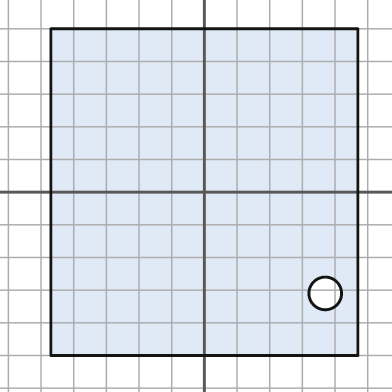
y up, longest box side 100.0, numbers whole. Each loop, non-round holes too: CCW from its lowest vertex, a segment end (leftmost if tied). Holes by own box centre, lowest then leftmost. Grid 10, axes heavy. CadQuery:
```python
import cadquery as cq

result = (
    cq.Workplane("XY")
    .moveTo(-47.0, -50.0)
    .lineTo(47.0, -50.0)
    .lineTo(47.0, 50.0)
    .lineTo(-47.0, 50.0)
    .close()
    .moveTo(37.0, -31.0)
    .circle(5.0)
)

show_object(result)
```